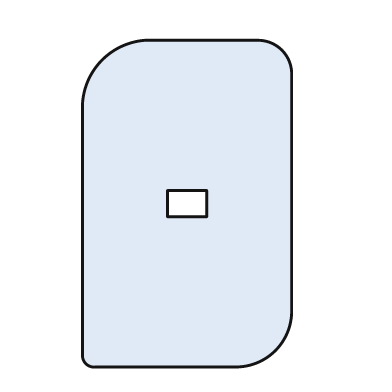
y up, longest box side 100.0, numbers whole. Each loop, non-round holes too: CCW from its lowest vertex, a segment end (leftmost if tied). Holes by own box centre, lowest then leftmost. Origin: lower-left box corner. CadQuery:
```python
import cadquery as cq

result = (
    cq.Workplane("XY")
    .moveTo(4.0, 0.0)
    .lineTo(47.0, 0.0)
    .threePointArc((59.0, 5.0), (64.0, 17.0))
    .lineTo(64.0, 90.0)
    .threePointArc((61.0, 97.0), (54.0, 100.0))
    .lineTo(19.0, 100.0)
    .threePointArc((6.0, 94.0), (0.0, 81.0))
    .lineTo(0.0, 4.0)
    .threePointArc((1.0, 1.0), (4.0, 0.0))
    .close()
    .moveTo(26.0, 46.0)
    .lineTo(38.0, 46.0)
    .lineTo(38.0, 54.0)
    .lineTo(26.0, 54.0)
    .close()
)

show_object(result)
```